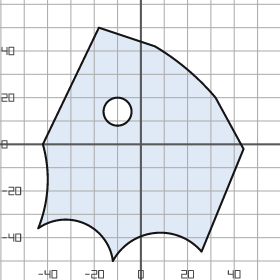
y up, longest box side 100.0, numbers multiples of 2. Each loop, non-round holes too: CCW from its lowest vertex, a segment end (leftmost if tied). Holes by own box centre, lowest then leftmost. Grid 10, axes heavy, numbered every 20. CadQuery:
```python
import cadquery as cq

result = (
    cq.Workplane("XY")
    .moveTo(-12.0, -50.0)
    .threePointArc((6.0, -38.0), (26.0, -46.0))
    .lineTo(44.0, -2.0)
    .lineTo(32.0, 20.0)
    .threePointArc((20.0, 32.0), (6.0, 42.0))
    .lineTo(-18.0, 50.0)
    .lineTo(-42.0, 0.0)
    .threePointArc((-40.0, -18.0), (-44.0, -36.0))
    .threePointArc((-24.0, -34.0), (-12.0, -50.0))
    .close()
    .moveTo(-10.0, 14.0)
    .circle(6.0)
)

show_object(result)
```